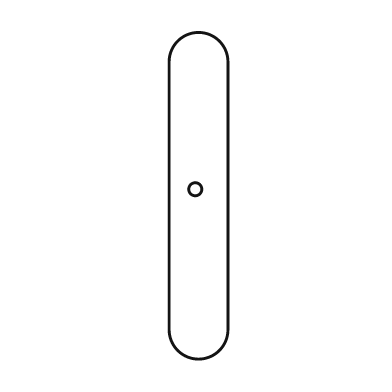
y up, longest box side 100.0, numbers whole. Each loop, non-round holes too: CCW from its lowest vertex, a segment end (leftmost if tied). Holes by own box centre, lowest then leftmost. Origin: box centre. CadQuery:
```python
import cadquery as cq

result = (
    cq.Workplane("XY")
    .moveTo(-9.0, -41.0)
    .threePointArc((0.0, -50.0), (9.0, -41.0))
    .lineTo(9.0, 41.0)
    .threePointArc((0.0, 50.0), (-9.0, 41.0))
    .close()
    .moveTo(-1.0, 2.0)
    .circle(2.0)
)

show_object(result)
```